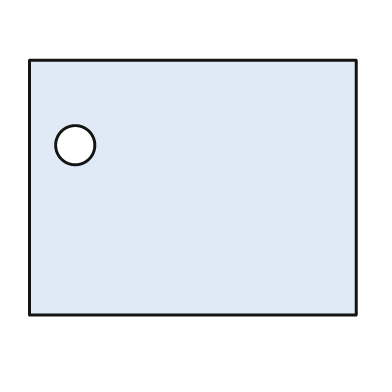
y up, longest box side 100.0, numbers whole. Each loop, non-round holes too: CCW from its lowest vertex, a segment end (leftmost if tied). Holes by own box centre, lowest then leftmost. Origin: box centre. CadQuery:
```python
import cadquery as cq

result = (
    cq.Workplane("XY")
    .moveTo(-50.0, -39.0)
    .lineTo(50.0, -39.0)
    .lineTo(50.0, 39.0)
    .lineTo(-50.0, 39.0)
    .close()
    .moveTo(-36.0, 13.0)
    .circle(6.0)
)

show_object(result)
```